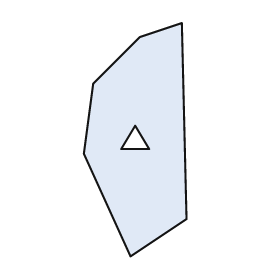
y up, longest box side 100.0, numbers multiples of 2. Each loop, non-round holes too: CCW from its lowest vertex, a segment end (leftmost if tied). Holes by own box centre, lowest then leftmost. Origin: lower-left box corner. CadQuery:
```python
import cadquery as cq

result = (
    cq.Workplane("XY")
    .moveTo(20.0, 0.0)
    .lineTo(44.0, 16.0)
    .lineTo(42.0, 100.0)
    .lineTo(24.0, 94.0)
    .lineTo(4.0, 74.0)
    .lineTo(0.0, 44.0)
    .close()
    .moveTo(16.0, 46.0)
    .lineTo(28.0, 46.0)
    .lineTo(22.0, 56.0)
    .close()
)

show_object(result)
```